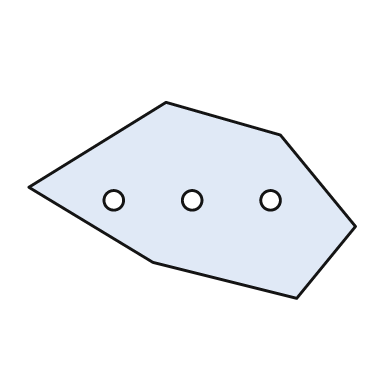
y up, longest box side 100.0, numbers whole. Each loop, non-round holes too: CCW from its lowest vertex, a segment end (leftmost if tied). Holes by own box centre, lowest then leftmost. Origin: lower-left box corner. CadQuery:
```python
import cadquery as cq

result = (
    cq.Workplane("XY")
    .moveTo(82.0, 0.0)
    .lineTo(100.0, 22.0)
    .lineTo(77.0, 50.0)
    .lineTo(42.0, 60.0)
    .lineTo(0.0, 34.0)
    .lineTo(38.0, 11.0)
    .close()
    .moveTo(26.0, 30.0)
    .circle(3.0)
    .moveTo(50.0, 30.0)
    .circle(3.0)
    .moveTo(74.0, 30.0)
    .circle(3.0)
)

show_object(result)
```